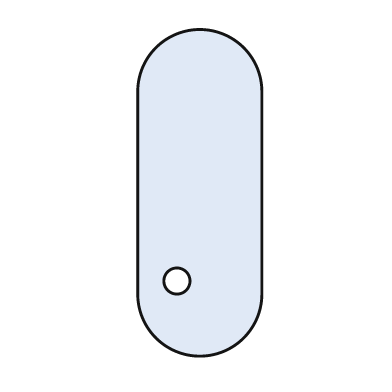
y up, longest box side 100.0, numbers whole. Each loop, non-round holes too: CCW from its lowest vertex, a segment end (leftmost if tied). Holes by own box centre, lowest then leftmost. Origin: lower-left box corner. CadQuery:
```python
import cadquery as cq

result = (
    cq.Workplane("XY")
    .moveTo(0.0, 19.0)
    .threePointArc((19.0, 0.0), (38.0, 19.0))
    .lineTo(38.0, 81.0)
    .threePointArc((19.0, 100.0), (0.0, 81.0))
    .close()
    .moveTo(12.0, 23.0)
    .circle(4.0)
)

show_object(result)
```